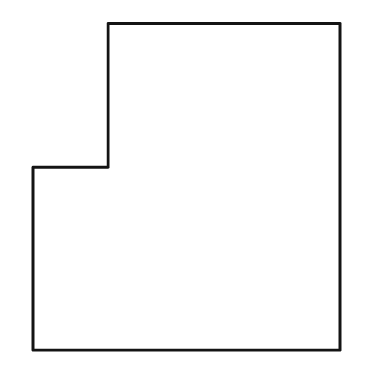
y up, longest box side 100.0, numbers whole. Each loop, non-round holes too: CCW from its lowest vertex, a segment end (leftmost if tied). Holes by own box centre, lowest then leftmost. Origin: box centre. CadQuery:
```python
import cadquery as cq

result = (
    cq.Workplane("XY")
    .moveTo(-47.0, -50.0)
    .lineTo(47.0, -50.0)
    .lineTo(47.0, 50.0)
    .lineTo(-24.0, 50.0)
    .lineTo(-24.0, 6.0)
    .lineTo(-47.0, 6.0)
    .close()
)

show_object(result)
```